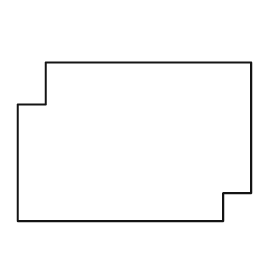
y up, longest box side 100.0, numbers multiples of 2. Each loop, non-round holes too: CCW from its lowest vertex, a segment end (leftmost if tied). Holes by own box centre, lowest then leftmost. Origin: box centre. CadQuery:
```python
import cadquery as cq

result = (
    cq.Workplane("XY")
    .moveTo(-50.0, -34.0)
    .lineTo(38.0, -34.0)
    .lineTo(38.0, -22.0)
    .lineTo(50.0, -22.0)
    .lineTo(50.0, 34.0)
    .lineTo(-38.0, 34.0)
    .lineTo(-38.0, 16.0)
    .lineTo(-50.0, 16.0)
    .close()
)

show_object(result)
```